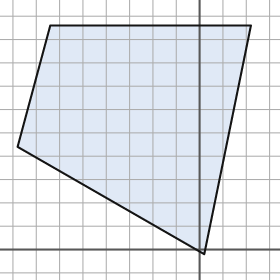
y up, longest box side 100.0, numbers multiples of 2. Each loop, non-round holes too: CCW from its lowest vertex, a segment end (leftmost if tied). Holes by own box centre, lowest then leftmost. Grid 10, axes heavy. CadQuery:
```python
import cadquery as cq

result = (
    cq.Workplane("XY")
    .moveTo(2.0, -2.0)
    .lineTo(22.0, 96.0)
    .lineTo(-64.0, 96.0)
    .lineTo(-78.0, 44.0)
    .close()
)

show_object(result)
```